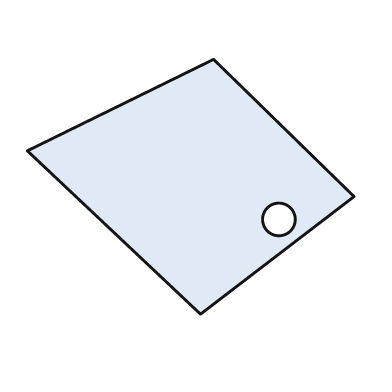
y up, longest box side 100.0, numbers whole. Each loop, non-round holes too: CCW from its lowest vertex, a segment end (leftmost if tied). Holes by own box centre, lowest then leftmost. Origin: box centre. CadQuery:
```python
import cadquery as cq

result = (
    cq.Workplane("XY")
    .moveTo(3.0, -39.0)
    .lineTo(50.0, -3.0)
    .lineTo(7.0, 39.0)
    .lineTo(-50.0, 11.0)
    .close()
    .moveTo(27.0, -10.0)
    .circle(5.0)
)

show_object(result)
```